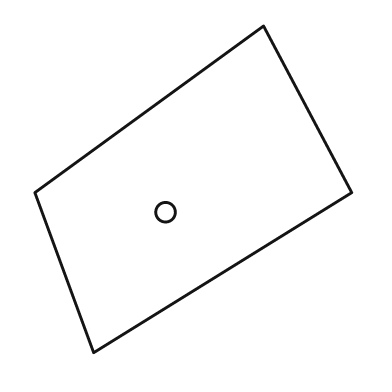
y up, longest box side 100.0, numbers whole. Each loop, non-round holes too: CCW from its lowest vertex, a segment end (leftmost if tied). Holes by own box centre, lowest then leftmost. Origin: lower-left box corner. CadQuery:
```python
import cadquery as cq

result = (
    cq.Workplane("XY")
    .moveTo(18.0, 0.0)
    .lineTo(97.0, 49.0)
    .lineTo(70.0, 100.0)
    .lineTo(0.0, 49.0)
    .close()
    .moveTo(40.0, 43.0)
    .circle(3.0)
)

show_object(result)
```